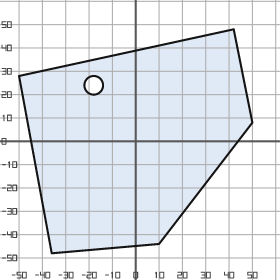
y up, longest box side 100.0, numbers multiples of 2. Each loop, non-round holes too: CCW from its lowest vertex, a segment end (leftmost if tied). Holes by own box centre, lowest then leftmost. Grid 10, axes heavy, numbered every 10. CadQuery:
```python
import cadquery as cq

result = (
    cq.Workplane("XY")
    .moveTo(-36.0, -48.0)
    .lineTo(10.0, -44.0)
    .lineTo(50.0, 8.0)
    .lineTo(42.0, 48.0)
    .lineTo(-50.0, 28.0)
    .close()
    .moveTo(-18.0, 24.0)
    .circle(4.0)
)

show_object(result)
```